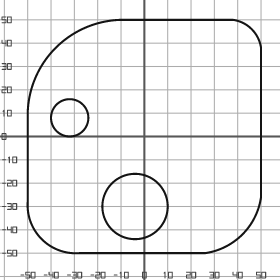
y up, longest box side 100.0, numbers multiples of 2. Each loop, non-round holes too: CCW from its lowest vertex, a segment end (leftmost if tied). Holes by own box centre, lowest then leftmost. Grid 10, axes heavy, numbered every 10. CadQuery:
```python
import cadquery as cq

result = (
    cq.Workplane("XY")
    .moveTo(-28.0, -50.0)
    .lineTo(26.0, -50.0)
    .threePointArc((42.0, -42.0), (50.0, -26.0))
    .lineTo(50.0, 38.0)
    .threePointArc((46.0, 46.0), (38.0, 50.0))
    .lineTo(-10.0, 50.0)
    .threePointArc((-38.0, 38.0), (-50.0, 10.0))
    .lineTo(-50.0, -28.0)
    .threePointArc((-44.0, -44.0), (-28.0, -50.0))
    .close()
    .moveTo(-4.0, -30.0)
    .circle(14.0)
    .moveTo(-32.0, 8.0)
    .circle(8.0)
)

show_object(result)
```